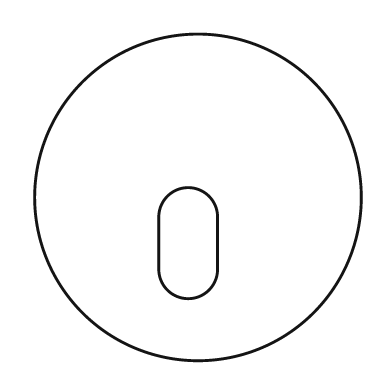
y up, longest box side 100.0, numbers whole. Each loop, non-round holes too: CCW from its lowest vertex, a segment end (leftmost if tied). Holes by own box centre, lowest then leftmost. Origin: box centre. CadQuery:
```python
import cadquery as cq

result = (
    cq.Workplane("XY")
    .moveTo(0.0, 0.0)
    .circle(50.0)
    .moveTo(-12.0, -22.0)
    .threePointArc((-3.0, -31.0), (6.0, -22.0))
    .lineTo(6.0, -6.0)
    .threePointArc((-3.0, 3.0), (-12.0, -6.0))
    .close()
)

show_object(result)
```